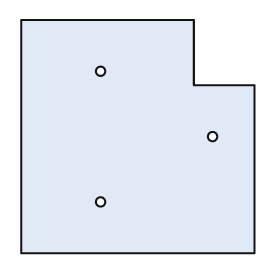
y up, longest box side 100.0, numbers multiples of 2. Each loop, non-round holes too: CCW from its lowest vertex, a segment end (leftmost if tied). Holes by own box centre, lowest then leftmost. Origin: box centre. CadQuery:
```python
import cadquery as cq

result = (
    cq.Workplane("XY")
    .moveTo(-50.0, -50.0)
    .lineTo(50.0, -50.0)
    .lineTo(50.0, 22.0)
    .lineTo(24.0, 22.0)
    .lineTo(24.0, 50.0)
    .lineTo(-50.0, 50.0)
    .close()
    .moveTo(-16.0, -28.0)
    .circle(2.0)
    .moveTo(32.0, 0.0)
    .circle(2.0)
    .moveTo(-16.0, 28.0)
    .circle(2.0)
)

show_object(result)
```